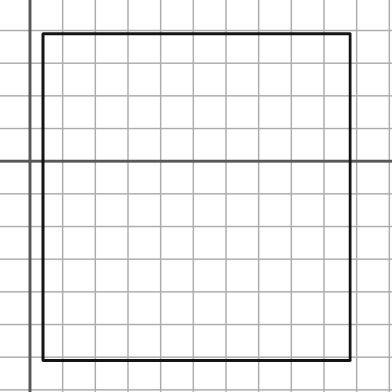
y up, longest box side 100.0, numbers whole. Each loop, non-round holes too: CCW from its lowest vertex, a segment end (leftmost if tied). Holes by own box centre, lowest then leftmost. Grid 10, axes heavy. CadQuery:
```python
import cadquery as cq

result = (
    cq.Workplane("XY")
    .moveTo(4.0, -61.0)
    .lineTo(98.0, -61.0)
    .lineTo(98.0, 39.0)
    .lineTo(4.0, 39.0)
    .close()
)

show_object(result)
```